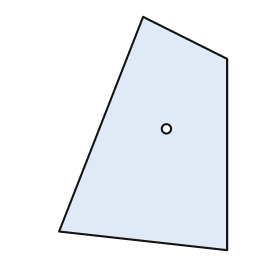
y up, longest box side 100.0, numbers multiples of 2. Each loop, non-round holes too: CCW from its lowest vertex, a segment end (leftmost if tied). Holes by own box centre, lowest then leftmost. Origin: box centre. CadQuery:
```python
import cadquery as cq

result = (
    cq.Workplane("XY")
    .moveTo(36.0, -50.0)
    .lineTo(36.0, 32.0)
    .lineTo(0.0, 50.0)
    .lineTo(-36.0, -42.0)
    .close()
    .moveTo(10.0, 2.0)
    .circle(2.0)
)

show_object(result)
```